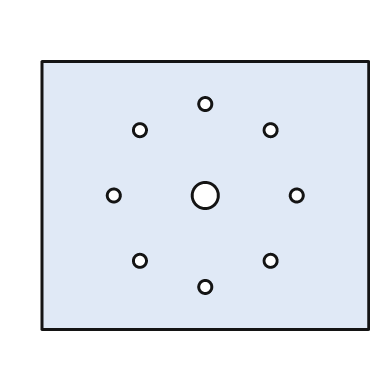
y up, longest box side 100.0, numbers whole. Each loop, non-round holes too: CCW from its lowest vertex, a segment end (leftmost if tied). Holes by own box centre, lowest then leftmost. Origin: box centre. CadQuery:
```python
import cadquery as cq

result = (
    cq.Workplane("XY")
    .moveTo(-50.0, -41.0)
    .lineTo(50.0, -41.0)
    .lineTo(50.0, 41.0)
    .lineTo(-50.0, 41.0)
    .close()
    .moveTo(0.0, -28.0)
    .circle(2.0)
    .moveTo(-20.0, -20.0)
    .circle(2.0)
    .moveTo(20.0, -20.0)
    .circle(2.0)
    .moveTo(-28.0, 0.0)
    .circle(2.0)
    .moveTo(0.0, 0.0)
    .circle(4.0)
    .moveTo(28.0, 0.0)
    .circle(2.0)
    .moveTo(-20.0, 20.0)
    .circle(2.0)
    .moveTo(20.0, 20.0)
    .circle(2.0)
    .moveTo(0.0, 28.0)
    .circle(2.0)
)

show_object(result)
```